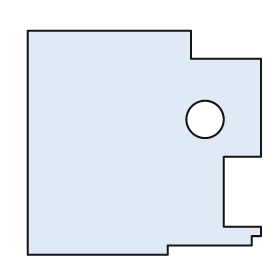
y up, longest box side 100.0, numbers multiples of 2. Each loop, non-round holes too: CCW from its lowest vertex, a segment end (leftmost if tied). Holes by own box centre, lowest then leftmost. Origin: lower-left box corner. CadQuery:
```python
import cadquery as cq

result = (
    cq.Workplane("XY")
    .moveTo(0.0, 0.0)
    .lineTo(60.0, 0.0)
    .lineTo(60.0, 4.0)
    .lineTo(96.0, 4.0)
    .lineTo(96.0, 8.0)
    .lineTo(100.0, 8.0)
    .lineTo(100.0, 12.0)
    .lineTo(84.0, 12.0)
    .lineTo(84.0, 42.0)
    .lineTo(100.0, 42.0)
    .lineTo(100.0, 84.0)
    .lineTo(70.0, 84.0)
    .lineTo(70.0, 96.0)
    .lineTo(0.0, 96.0)
    .close()
    .moveTo(76.0, 58.0)
    .circle(8.0)
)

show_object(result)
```